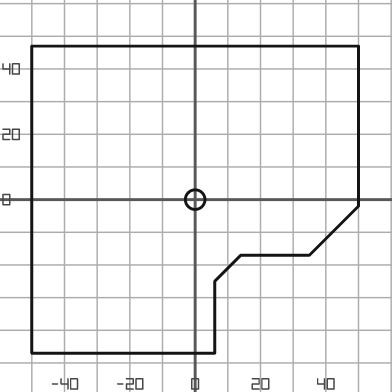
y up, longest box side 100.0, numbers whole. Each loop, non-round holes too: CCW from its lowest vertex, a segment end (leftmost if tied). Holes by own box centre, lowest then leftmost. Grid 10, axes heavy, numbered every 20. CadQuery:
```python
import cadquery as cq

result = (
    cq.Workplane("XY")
    .moveTo(-50.0, -47.0)
    .lineTo(6.0, -47.0)
    .lineTo(6.0, -25.0)
    .lineTo(14.0, -17.0)
    .lineTo(35.0, -17.0)
    .lineTo(50.0, -2.0)
    .lineTo(50.0, 47.0)
    .lineTo(-50.0, 47.0)
    .close()
    .moveTo(0.0, 0.0)
    .circle(3.0)
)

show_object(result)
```